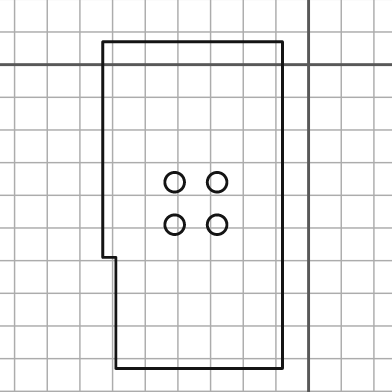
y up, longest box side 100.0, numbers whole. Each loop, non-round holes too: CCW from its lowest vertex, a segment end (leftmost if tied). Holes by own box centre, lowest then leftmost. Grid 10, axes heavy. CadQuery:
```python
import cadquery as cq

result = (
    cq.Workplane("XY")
    .moveTo(-59.0, -93.0)
    .lineTo(-8.0, -93.0)
    .lineTo(-8.0, 7.0)
    .lineTo(-63.0, 7.0)
    .lineTo(-63.0, -59.0)
    .lineTo(-59.0, -59.0)
    .close()
    .moveTo(-41.0, -49.0)
    .circle(3.0)
    .moveTo(-28.0, -49.0)
    .circle(3.0)
    .moveTo(-41.0, -36.0)
    .circle(3.0)
    .moveTo(-28.0, -36.0)
    .circle(3.0)
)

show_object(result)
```